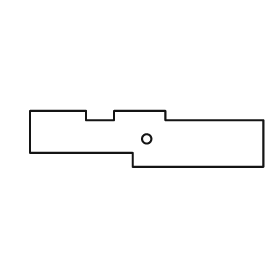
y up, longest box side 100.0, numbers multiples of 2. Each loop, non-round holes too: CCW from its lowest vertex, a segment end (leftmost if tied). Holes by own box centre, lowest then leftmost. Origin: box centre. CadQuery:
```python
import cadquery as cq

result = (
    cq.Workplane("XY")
    .moveTo(-6.0, -12.0)
    .lineTo(50.0, -12.0)
    .lineTo(50.0, 8.0)
    .lineTo(8.0, 8.0)
    .lineTo(8.0, 12.0)
    .lineTo(-14.0, 12.0)
    .lineTo(-14.0, 8.0)
    .lineTo(-26.0, 8.0)
    .lineTo(-26.0, 12.0)
    .lineTo(-50.0, 12.0)
    .lineTo(-50.0, -6.0)
    .lineTo(-6.0, -6.0)
    .close()
    .moveTo(0.0, 0.0)
    .circle(2.0)
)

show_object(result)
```